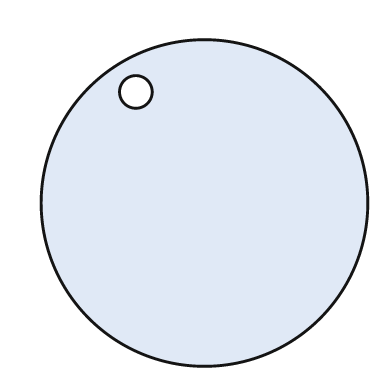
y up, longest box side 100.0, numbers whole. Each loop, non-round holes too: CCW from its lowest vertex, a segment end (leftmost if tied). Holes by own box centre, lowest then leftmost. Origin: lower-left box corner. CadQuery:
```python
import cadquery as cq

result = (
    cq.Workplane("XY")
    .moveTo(50.0, 50.0)
    .circle(50.0)
    .moveTo(29.0, 84.0)
    .circle(5.0)
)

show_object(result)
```